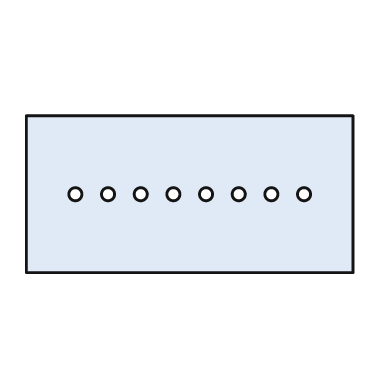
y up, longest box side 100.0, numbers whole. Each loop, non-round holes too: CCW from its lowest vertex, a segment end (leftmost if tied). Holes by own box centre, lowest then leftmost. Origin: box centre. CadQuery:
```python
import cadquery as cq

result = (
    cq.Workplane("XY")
    .moveTo(-50.0, -24.0)
    .lineTo(50.0, -24.0)
    .lineTo(50.0, 24.0)
    .lineTo(-50.0, 24.0)
    .close()
    .moveTo(-35.0, 0.0)
    .circle(2.0)
    .moveTo(-25.0, 0.0)
    .circle(2.0)
    .moveTo(-15.0, 0.0)
    .circle(2.0)
    .moveTo(-5.0, 0.0)
    .circle(2.0)
    .moveTo(5.0, 0.0)
    .circle(2.0)
    .moveTo(15.0, 0.0)
    .circle(2.0)
    .moveTo(25.0, 0.0)
    .circle(2.0)
    .moveTo(35.0, 0.0)
    .circle(2.0)
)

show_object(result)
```